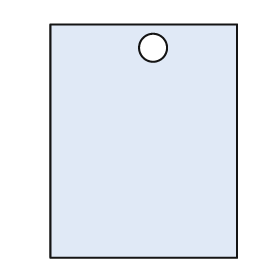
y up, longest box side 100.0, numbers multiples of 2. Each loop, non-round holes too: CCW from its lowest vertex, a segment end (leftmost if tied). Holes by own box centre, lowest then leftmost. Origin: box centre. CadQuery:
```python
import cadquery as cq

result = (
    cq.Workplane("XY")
    .moveTo(-40.0, -50.0)
    .lineTo(40.0, -50.0)
    .lineTo(40.0, 50.0)
    .lineTo(-40.0, 50.0)
    .close()
    .moveTo(4.0, 40.0)
    .circle(6.0)
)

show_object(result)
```